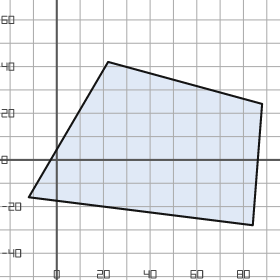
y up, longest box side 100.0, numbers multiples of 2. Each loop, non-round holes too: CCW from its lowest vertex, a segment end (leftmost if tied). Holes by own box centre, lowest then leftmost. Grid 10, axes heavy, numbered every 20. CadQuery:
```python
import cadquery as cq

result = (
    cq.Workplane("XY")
    .moveTo(84.0, -28.0)
    .lineTo(88.0, 24.0)
    .lineTo(22.0, 42.0)
    .lineTo(-12.0, -16.0)
    .close()
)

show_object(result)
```